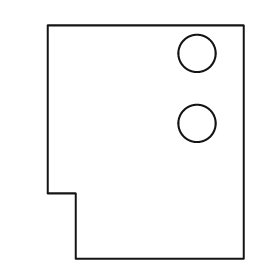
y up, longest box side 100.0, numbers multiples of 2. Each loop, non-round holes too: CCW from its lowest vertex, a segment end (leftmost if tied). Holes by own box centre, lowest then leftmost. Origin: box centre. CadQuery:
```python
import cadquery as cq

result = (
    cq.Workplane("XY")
    .moveTo(-30.0, -50.0)
    .lineTo(42.0, -50.0)
    .lineTo(42.0, 50.0)
    .lineTo(-42.0, 50.0)
    .lineTo(-42.0, -22.0)
    .lineTo(-30.0, -22.0)
    .close()
    .moveTo(22.0, 8.0)
    .circle(8.0)
    .moveTo(22.0, 38.0)
    .circle(8.0)
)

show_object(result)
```